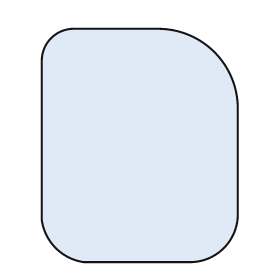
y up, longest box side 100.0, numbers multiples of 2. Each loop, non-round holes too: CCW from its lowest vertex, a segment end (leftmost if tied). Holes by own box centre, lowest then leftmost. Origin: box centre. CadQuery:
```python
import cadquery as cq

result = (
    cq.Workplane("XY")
    .moveTo(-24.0, -50.0)
    .lineTo(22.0, -50.0)
    .threePointArc((36.0, -44.0), (42.0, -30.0))
    .lineTo(42.0, 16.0)
    .threePointArc((32.0, 40.0), (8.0, 50.0))
    .lineTo(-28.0, 50.0)
    .threePointArc((-38.0, 46.0), (-42.0, 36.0))
    .lineTo(-42.0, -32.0)
    .threePointArc((-36.0, -44.0), (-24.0, -50.0))
    .close()
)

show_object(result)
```